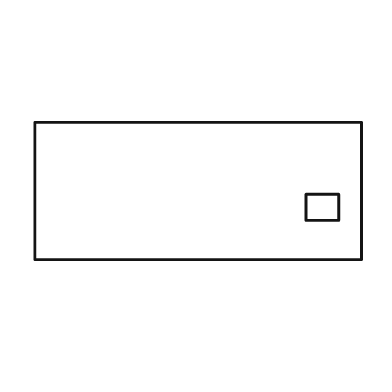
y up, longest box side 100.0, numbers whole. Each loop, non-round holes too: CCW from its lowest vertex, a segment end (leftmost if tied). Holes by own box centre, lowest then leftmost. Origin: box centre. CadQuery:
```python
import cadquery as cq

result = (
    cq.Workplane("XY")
    .moveTo(-50.0, -21.0)
    .lineTo(50.0, -21.0)
    .lineTo(50.0, 21.0)
    .lineTo(-50.0, 21.0)
    .close()
    .moveTo(33.0, -9.0)
    .lineTo(43.0, -9.0)
    .lineTo(43.0, -1.0)
    .lineTo(33.0, -1.0)
    .close()
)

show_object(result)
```